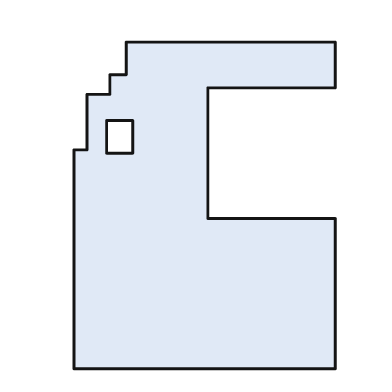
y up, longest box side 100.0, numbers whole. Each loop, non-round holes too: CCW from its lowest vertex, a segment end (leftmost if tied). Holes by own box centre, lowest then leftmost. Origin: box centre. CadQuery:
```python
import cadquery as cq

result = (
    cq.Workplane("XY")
    .moveTo(-40.0, -50.0)
    .lineTo(40.0, -50.0)
    .lineTo(40.0, -4.0)
    .lineTo(1.0, -4.0)
    .lineTo(1.0, 36.0)
    .lineTo(40.0, 36.0)
    .lineTo(40.0, 50.0)
    .lineTo(-24.0, 50.0)
    .lineTo(-24.0, 40.0)
    .lineTo(-29.0, 40.0)
    .lineTo(-29.0, 34.0)
    .lineTo(-36.0, 34.0)
    .lineTo(-36.0, 17.0)
    .lineTo(-40.0, 17.0)
    .close()
    .moveTo(-30.0, 16.0)
    .lineTo(-22.0, 16.0)
    .lineTo(-22.0, 26.0)
    .lineTo(-30.0, 26.0)
    .close()
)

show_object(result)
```